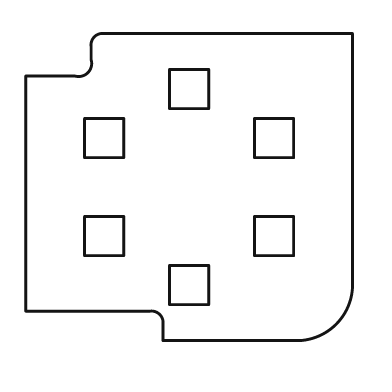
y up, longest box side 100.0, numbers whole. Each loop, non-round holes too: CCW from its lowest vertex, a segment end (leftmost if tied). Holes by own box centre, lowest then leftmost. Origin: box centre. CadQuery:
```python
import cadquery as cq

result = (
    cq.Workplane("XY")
    .moveTo(-8.0, -47.0)
    .lineTo(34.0, -47.0)
    .threePointArc((45.0, -42.0), (50.0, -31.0))
    .lineTo(50.0, 47.0)
    .lineTo(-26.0, 47.0)
    .threePointArc((-29.0, 46.0), (-30.0, 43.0))
    .lineTo(-30.0, 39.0)
    .threePointArc((-31.0, 35.0), (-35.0, 34.0))
    .lineTo(-50.0, 34.0)
    .lineTo(-50.0, -38.0)
    .lineTo(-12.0, -38.0)
    .threePointArc((-9.0, -39.0), (-8.0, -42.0))
    .close()
    .moveTo(-6.0, -36.0)
    .lineTo(6.0, -36.0)
    .lineTo(6.0, -24.0)
    .lineTo(-6.0, -24.0)
    .close()
    .moveTo(-32.0, -21.0)
    .lineTo(-20.0, -21.0)
    .lineTo(-20.0, -9.0)
    .lineTo(-32.0, -9.0)
    .close()
    .moveTo(20.0, -21.0)
    .lineTo(32.0, -21.0)
    .lineTo(32.0, -9.0)
    .lineTo(20.0, -9.0)
    .close()
    .moveTo(-32.0, 9.0)
    .lineTo(-20.0, 9.0)
    .lineTo(-20.0, 21.0)
    .lineTo(-32.0, 21.0)
    .close()
    .moveTo(20.0, 9.0)
    .lineTo(32.0, 9.0)
    .lineTo(32.0, 21.0)
    .lineTo(20.0, 21.0)
    .close()
    .moveTo(-6.0, 24.0)
    .lineTo(6.0, 24.0)
    .lineTo(6.0, 36.0)
    .lineTo(-6.0, 36.0)
    .close()
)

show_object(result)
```